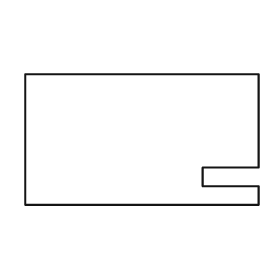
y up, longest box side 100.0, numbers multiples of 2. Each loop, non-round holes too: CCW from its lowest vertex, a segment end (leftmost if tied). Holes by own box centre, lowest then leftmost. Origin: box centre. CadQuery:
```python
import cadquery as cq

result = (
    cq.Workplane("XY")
    .moveTo(-50.0, -28.0)
    .lineTo(50.0, -28.0)
    .lineTo(50.0, -20.0)
    .lineTo(26.0, -20.0)
    .lineTo(26.0, -12.0)
    .lineTo(50.0, -12.0)
    .lineTo(50.0, 28.0)
    .lineTo(-50.0, 28.0)
    .close()
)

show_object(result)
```